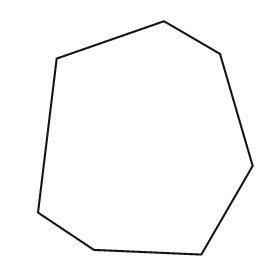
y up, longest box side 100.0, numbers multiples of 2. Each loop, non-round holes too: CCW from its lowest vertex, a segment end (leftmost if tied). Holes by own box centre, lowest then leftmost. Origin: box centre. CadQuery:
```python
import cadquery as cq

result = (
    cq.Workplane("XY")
    .moveTo(24.0, -50.0)
    .lineTo(46.0, -12.0)
    .lineTo(32.0, 36.0)
    .lineTo(8.0, 50.0)
    .lineTo(-38.0, 34.0)
    .lineTo(-46.0, -32.0)
    .lineTo(-22.0, -48.0)
    .close()
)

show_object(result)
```